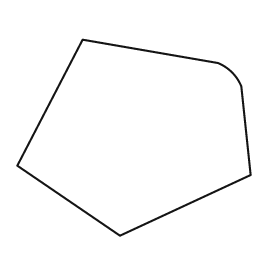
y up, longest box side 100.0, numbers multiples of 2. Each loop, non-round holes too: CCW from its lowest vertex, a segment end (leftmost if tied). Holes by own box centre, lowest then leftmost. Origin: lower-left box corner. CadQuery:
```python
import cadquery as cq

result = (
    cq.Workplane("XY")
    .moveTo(44.0, 0.0)
    .lineTo(100.0, 26.0)
    .lineTo(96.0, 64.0)
    .threePointArc((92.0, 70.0), (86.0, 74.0))
    .lineTo(28.0, 84.0)
    .lineTo(0.0, 30.0)
    .close()
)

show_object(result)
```